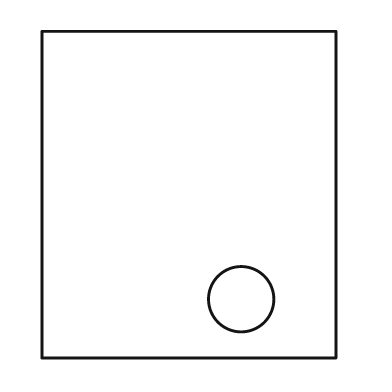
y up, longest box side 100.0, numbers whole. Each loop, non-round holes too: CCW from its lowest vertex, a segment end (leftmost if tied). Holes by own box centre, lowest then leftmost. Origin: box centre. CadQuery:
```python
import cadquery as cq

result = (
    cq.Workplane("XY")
    .moveTo(-45.0, -50.0)
    .lineTo(45.0, -50.0)
    .lineTo(45.0, 50.0)
    .lineTo(-45.0, 50.0)
    .close()
    .moveTo(16.0, -32.0)
    .circle(10.0)
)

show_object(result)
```